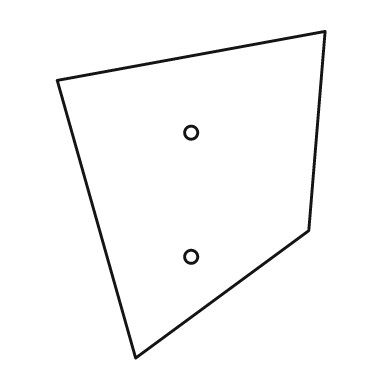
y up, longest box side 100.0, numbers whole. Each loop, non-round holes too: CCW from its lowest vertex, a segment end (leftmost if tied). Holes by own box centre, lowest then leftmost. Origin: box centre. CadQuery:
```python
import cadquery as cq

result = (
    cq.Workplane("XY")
    .moveTo(-17.0, -50.0)
    .lineTo(36.0, -11.0)
    .lineTo(41.0, 50.0)
    .lineTo(-41.0, 35.0)
    .close()
    .moveTo(0.0, -19.0)
    .circle(2.0)
    .moveTo(0.0, 19.0)
    .circle(2.0)
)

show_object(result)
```